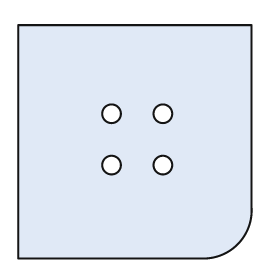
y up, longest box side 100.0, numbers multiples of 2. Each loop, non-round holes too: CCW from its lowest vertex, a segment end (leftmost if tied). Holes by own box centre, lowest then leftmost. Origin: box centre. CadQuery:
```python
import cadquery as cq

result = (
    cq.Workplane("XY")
    .moveTo(-50.0, -50.0)
    .lineTo(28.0, -50.0)
    .threePointArc((44.0, -44.0), (50.0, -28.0))
    .lineTo(50.0, 50.0)
    .lineTo(-50.0, 50.0)
    .close()
    .moveTo(-10.0, -10.0)
    .circle(4.0)
    .moveTo(12.0, -10.0)
    .circle(4.0)
    .moveTo(-10.0, 12.0)
    .circle(4.0)
    .moveTo(12.0, 12.0)
    .circle(4.0)
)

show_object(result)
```